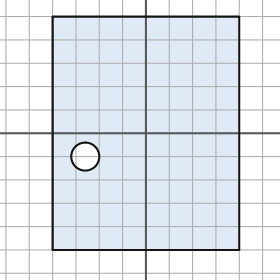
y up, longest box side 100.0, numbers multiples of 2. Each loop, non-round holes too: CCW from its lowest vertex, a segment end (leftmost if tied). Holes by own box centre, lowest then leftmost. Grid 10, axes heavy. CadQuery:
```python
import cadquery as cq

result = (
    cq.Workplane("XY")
    .moveTo(-40.0, -50.0)
    .lineTo(40.0, -50.0)
    .lineTo(40.0, 50.0)
    .lineTo(-40.0, 50.0)
    .close()
    .moveTo(-26.0, -10.0)
    .circle(6.0)
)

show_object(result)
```